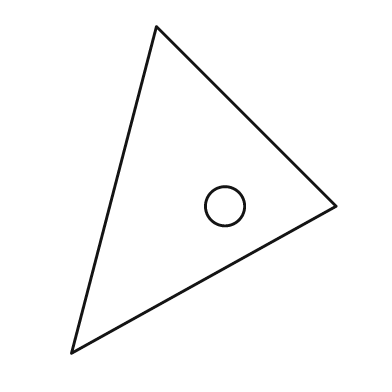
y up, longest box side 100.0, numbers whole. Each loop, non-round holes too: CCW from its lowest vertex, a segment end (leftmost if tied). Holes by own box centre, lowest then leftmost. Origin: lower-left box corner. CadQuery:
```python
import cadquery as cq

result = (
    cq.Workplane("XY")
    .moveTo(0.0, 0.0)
    .lineTo(81.0, 45.0)
    .lineTo(26.0, 100.0)
    .close()
    .moveTo(47.0, 45.0)
    .circle(6.0)
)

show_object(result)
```